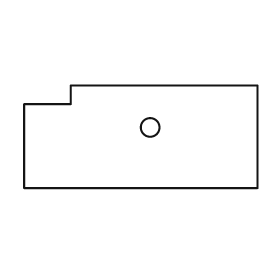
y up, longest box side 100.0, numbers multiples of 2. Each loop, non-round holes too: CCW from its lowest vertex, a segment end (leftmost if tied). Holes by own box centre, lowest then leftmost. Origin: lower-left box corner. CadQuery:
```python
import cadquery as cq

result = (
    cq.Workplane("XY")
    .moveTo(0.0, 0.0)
    .lineTo(100.0, 0.0)
    .lineTo(100.0, 44.0)
    .lineTo(20.0, 44.0)
    .lineTo(20.0, 36.0)
    .lineTo(0.0, 36.0)
    .close()
    .moveTo(54.0, 26.0)
    .circle(4.0)
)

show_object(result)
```